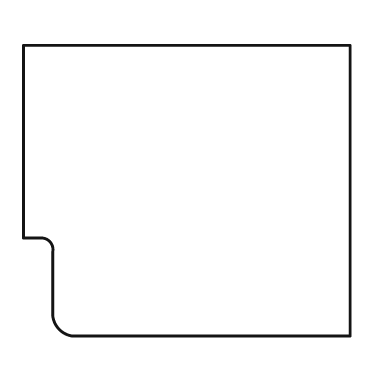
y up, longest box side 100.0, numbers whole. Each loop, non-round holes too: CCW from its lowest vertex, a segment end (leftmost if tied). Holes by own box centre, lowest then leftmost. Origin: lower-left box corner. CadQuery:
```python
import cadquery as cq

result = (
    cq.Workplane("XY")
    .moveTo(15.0, 0.0)
    .lineTo(100.0, 0.0)
    .lineTo(100.0, 89.0)
    .lineTo(0.0, 89.0)
    .lineTo(0.0, 30.0)
    .lineTo(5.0, 30.0)
    .threePointArc((8.0, 29.0), (9.0, 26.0))
    .lineTo(9.0, 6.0)
    .threePointArc((11.0, 2.0), (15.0, 0.0))
    .close()
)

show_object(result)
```